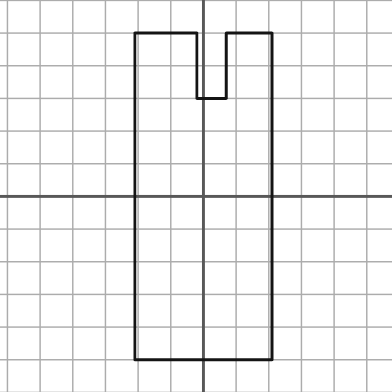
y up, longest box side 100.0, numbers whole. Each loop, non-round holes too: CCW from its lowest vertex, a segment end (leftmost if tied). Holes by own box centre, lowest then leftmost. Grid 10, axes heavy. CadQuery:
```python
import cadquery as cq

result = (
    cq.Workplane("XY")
    .moveTo(-21.0, -50.0)
    .lineTo(21.0, -50.0)
    .lineTo(21.0, 50.0)
    .lineTo(7.0, 50.0)
    .lineTo(7.0, 30.0)
    .lineTo(-2.0, 30.0)
    .lineTo(-2.0, 50.0)
    .lineTo(-21.0, 50.0)
    .close()
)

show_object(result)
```